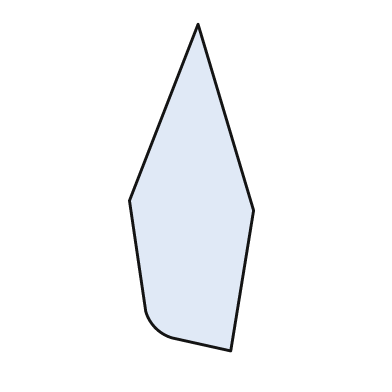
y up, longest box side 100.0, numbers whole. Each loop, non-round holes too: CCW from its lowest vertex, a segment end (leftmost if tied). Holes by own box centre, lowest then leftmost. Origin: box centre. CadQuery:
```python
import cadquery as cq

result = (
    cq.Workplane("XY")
    .moveTo(12.0, -50.0)
    .lineTo(19.0, -7.0)
    .lineTo(2.0, 50.0)
    .lineTo(-19.0, -4.0)
    .lineTo(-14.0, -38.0)
    .threePointArc((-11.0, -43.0), (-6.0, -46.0))
    .close()
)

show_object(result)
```